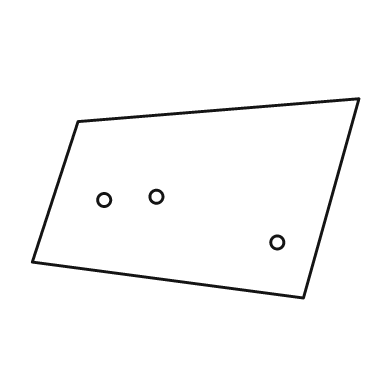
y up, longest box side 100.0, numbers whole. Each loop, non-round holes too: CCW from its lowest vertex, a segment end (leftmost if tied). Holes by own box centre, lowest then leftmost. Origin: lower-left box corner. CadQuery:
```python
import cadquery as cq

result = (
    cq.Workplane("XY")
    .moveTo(83.0, 0.0)
    .lineTo(100.0, 61.0)
    .lineTo(14.0, 54.0)
    .lineTo(0.0, 11.0)
    .close()
    .moveTo(75.0, 17.0)
    .circle(2.0)
    .moveTo(22.0, 30.0)
    .circle(2.0)
    .moveTo(38.0, 31.0)
    .circle(2.0)
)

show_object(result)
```